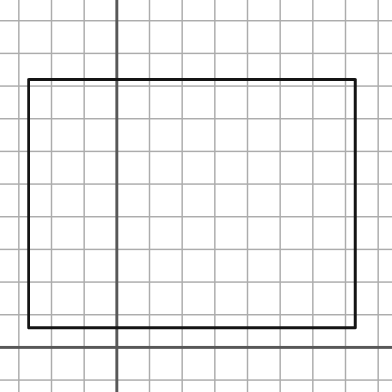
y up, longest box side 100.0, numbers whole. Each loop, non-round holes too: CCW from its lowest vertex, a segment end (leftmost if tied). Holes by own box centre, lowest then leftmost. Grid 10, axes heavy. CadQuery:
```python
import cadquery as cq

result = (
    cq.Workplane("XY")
    .moveTo(-27.0, 6.0)
    .lineTo(73.0, 6.0)
    .lineTo(73.0, 82.0)
    .lineTo(-27.0, 82.0)
    .close()
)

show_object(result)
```